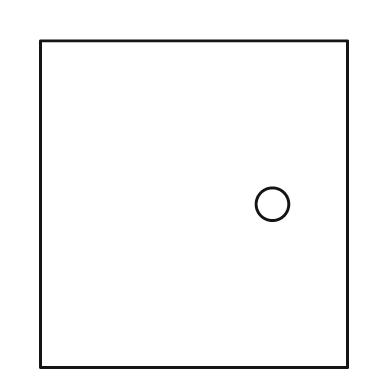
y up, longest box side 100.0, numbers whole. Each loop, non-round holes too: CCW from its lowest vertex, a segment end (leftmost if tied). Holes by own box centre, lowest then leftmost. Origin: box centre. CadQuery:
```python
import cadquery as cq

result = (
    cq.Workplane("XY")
    .moveTo(-47.0, -50.0)
    .lineTo(47.0, -50.0)
    .lineTo(47.0, 50.0)
    .lineTo(-47.0, 50.0)
    .close()
    .moveTo(24.0, 0.0)
    .circle(5.0)
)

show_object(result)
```